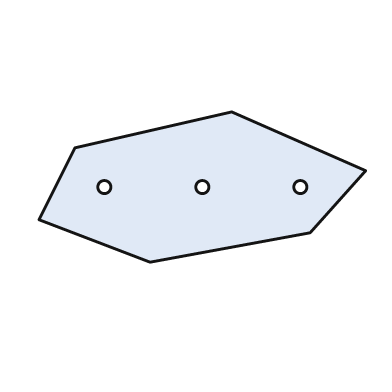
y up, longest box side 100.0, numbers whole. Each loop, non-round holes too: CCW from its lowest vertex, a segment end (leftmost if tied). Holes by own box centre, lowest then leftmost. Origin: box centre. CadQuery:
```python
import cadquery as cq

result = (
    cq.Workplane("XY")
    .moveTo(-16.0, -23.0)
    .lineTo(33.0, -14.0)
    .lineTo(50.0, 5.0)
    .lineTo(9.0, 23.0)
    .lineTo(-39.0, 12.0)
    .lineTo(-50.0, -10.0)
    .close()
    .moveTo(-30.0, 0.0)
    .circle(2.0)
    .moveTo(0.0, 0.0)
    .circle(2.0)
    .moveTo(30.0, 0.0)
    .circle(2.0)
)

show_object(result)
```